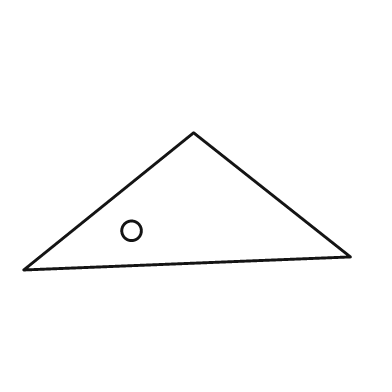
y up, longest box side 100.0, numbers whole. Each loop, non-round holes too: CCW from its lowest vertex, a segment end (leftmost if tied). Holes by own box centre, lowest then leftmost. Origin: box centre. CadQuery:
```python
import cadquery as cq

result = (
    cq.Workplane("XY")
    .moveTo(-50.0, -21.0)
    .lineTo(50.0, -17.0)
    .lineTo(2.0, 21.0)
    .close()
    .moveTo(-17.0, -9.0)
    .circle(3.0)
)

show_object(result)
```